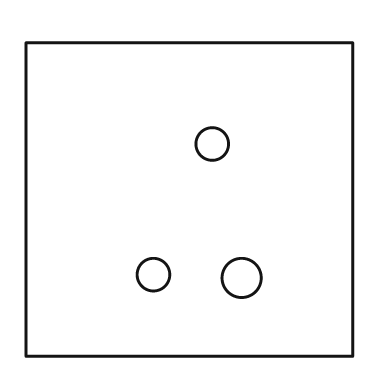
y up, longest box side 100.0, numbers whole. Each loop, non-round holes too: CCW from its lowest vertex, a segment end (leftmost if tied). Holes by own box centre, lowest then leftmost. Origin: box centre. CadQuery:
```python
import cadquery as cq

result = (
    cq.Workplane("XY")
    .moveTo(-50.0, -48.0)
    .lineTo(50.0, -48.0)
    .lineTo(50.0, 48.0)
    .lineTo(-50.0, 48.0)
    .close()
    .moveTo(16.0, -24.0)
    .circle(6.0)
    .moveTo(-11.0, -23.0)
    .circle(5.0)
    .moveTo(7.0, 17.0)
    .circle(5.0)
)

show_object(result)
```